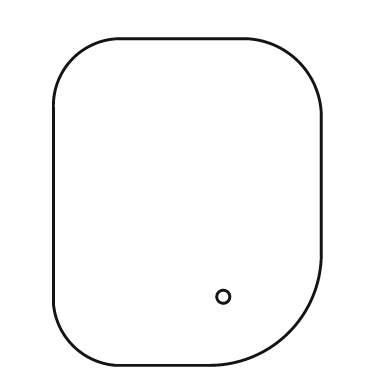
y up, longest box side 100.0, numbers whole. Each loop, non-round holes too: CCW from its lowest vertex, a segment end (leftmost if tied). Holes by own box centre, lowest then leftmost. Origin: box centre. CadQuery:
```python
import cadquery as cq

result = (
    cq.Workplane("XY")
    .moveTo(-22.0, -50.0)
    .lineTo(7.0, -50.0)
    .threePointArc((31.0, -40.0), (41.0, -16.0))
    .lineTo(41.0, 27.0)
    .threePointArc((34.0, 43.0), (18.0, 50.0))
    .lineTo(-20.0, 50.0)
    .threePointArc((-35.0, 44.0), (-41.0, 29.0))
    .lineTo(-41.0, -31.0)
    .threePointArc((-35.0, -44.0), (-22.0, -50.0))
    .close()
    .moveTo(11.0, -29.0)
    .circle(2.0)
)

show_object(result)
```